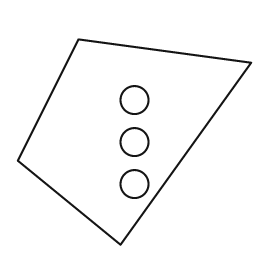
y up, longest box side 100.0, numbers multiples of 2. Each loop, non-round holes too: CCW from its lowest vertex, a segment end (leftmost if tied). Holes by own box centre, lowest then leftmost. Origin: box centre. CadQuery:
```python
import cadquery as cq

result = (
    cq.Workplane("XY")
    .moveTo(-6.0, -44.0)
    .lineTo(50.0, 34.0)
    .lineTo(-24.0, 44.0)
    .lineTo(-50.0, -8.0)
    .close()
    .moveTo(0.0, -18.0)
    .circle(6.0)
    .moveTo(0.0, 0.0)
    .circle(6.0)
    .moveTo(0.0, 18.0)
    .circle(6.0)
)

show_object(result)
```